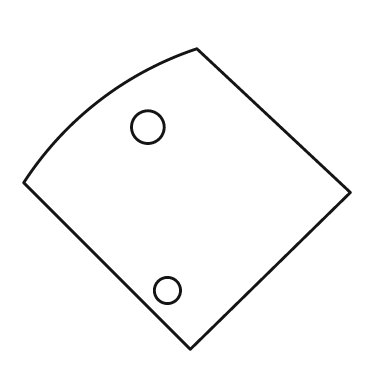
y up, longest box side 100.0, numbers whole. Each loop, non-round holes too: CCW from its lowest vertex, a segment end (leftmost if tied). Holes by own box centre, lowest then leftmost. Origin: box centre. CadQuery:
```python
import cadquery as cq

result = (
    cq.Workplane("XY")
    .moveTo(1.0, -46.0)
    .lineTo(50.0, 2.0)
    .lineTo(3.0, 46.0)
    .threePointArc((-27.0, 30.0), (-50.0, 5.0))
    .close()
    .moveTo(-6.0, -28.0)
    .circle(4.0)
    .moveTo(-12.0, 22.0)
    .circle(5.0)
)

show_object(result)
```